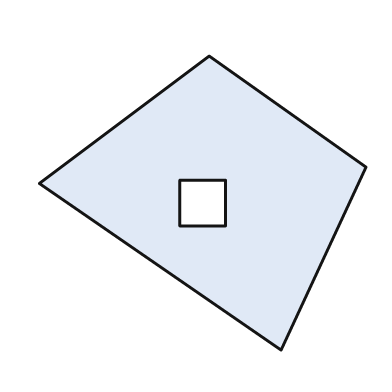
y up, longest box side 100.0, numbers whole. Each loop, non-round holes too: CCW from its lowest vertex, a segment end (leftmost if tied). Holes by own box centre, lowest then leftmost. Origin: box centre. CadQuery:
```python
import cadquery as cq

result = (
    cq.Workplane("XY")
    .moveTo(24.0, -45.0)
    .lineTo(50.0, 11.0)
    .lineTo(2.0, 45.0)
    .lineTo(-50.0, 6.0)
    .close()
    .moveTo(-7.0, -7.0)
    .lineTo(7.0, -7.0)
    .lineTo(7.0, 7.0)
    .lineTo(-7.0, 7.0)
    .close()
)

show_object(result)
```